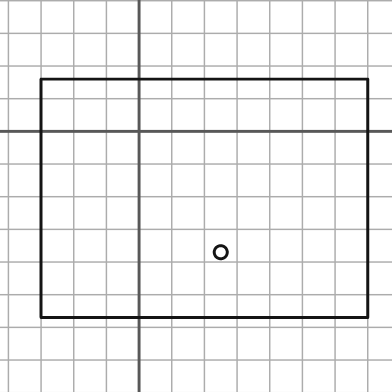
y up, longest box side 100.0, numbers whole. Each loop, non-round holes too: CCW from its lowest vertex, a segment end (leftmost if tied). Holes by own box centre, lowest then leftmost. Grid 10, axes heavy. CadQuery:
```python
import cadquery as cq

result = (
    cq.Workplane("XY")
    .moveTo(-30.0, -57.0)
    .lineTo(70.0, -57.0)
    .lineTo(70.0, 16.0)
    .lineTo(-30.0, 16.0)
    .close()
    .moveTo(25.0, -37.0)
    .circle(2.0)
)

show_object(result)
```